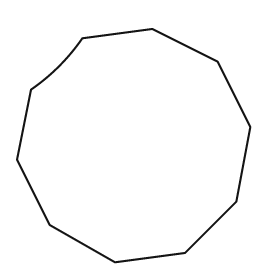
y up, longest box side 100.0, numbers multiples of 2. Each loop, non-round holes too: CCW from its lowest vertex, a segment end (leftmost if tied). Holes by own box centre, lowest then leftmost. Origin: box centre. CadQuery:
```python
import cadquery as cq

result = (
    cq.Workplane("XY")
    .moveTo(-8.0, -50.0)
    .lineTo(22.0, -46.0)
    .lineTo(44.0, -24.0)
    .lineTo(50.0, 8.0)
    .lineTo(36.0, 36.0)
    .lineTo(8.0, 50.0)
    .lineTo(-22.0, 46.0)
    .threePointArc((-32.0, 34.0), (-44.0, 24.0))
    .lineTo(-50.0, -6.0)
    .lineTo(-36.0, -34.0)
    .close()
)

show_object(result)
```